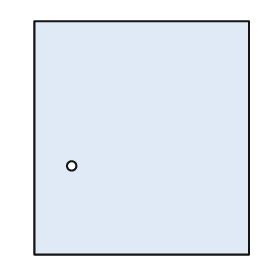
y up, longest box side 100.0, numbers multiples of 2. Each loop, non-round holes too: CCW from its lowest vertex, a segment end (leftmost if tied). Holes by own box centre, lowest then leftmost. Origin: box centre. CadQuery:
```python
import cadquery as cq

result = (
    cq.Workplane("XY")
    .moveTo(-46.0, -50.0)
    .lineTo(46.0, -50.0)
    .lineTo(46.0, 50.0)
    .lineTo(-46.0, 50.0)
    .close()
    .moveTo(-30.0, -12.0)
    .circle(2.0)
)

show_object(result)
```